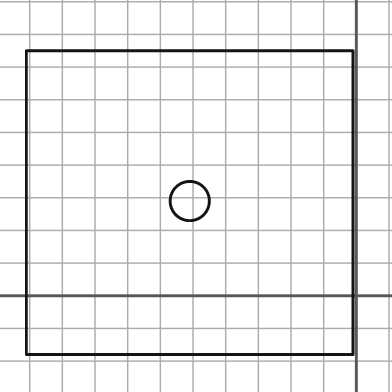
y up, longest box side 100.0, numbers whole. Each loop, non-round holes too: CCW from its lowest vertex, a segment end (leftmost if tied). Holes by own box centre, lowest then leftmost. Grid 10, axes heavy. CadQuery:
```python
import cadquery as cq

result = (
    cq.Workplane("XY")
    .moveTo(-101.0, -18.0)
    .lineTo(-1.0, -18.0)
    .lineTo(-1.0, 75.0)
    .lineTo(-101.0, 75.0)
    .close()
    .moveTo(-51.0, 29.0)
    .circle(6.0)
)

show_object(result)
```